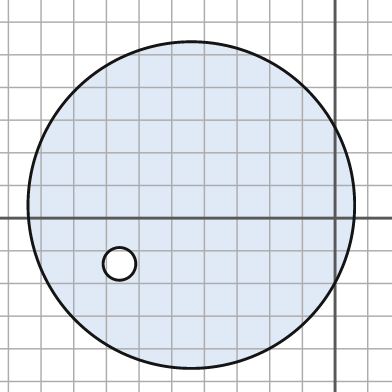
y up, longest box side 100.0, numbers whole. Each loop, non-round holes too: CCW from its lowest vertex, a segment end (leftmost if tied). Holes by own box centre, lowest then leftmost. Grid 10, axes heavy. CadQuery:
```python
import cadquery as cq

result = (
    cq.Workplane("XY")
    .moveTo(-44.0, 4.0)
    .circle(50.0)
    .moveTo(-66.0, -14.0)
    .circle(5.0)
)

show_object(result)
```